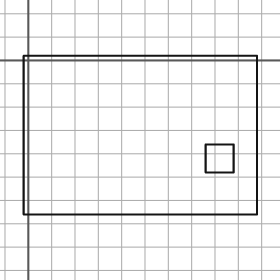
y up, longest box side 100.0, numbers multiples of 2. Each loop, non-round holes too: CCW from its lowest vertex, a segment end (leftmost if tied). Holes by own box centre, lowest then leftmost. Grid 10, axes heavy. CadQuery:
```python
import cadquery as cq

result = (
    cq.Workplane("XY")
    .moveTo(-2.0, -66.0)
    .lineTo(98.0, -66.0)
    .lineTo(98.0, 2.0)
    .lineTo(-2.0, 2.0)
    .close()
    .moveTo(76.0, -48.0)
    .lineTo(88.0, -48.0)
    .lineTo(88.0, -36.0)
    .lineTo(76.0, -36.0)
    .close()
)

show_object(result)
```